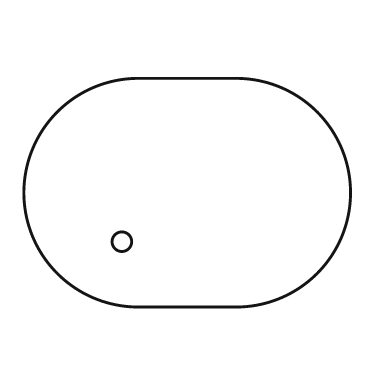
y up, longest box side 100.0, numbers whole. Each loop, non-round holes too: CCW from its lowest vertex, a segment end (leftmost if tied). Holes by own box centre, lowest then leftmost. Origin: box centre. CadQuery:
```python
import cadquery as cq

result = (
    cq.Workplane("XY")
    .moveTo(-15.0, -35.0)
    .lineTo(15.0, -35.0)
    .threePointArc((50.0, 0.0), (15.0, 35.0))
    .lineTo(-15.0, 35.0)
    .threePointArc((-50.0, 0.0), (-15.0, -35.0))
    .close()
    .moveTo(-20.0, -15.0)
    .circle(3.0)
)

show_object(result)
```